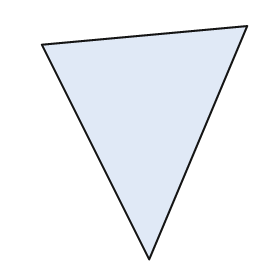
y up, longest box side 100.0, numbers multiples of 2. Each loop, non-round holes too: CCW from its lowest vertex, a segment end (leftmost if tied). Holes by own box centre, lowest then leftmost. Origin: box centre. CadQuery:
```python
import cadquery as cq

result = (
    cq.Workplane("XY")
    .moveTo(2.0, -50.0)
    .lineTo(44.0, 50.0)
    .lineTo(-44.0, 42.0)
    .close()
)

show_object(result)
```